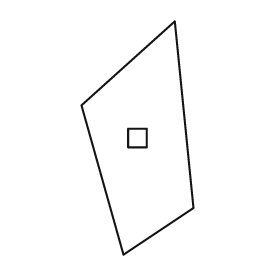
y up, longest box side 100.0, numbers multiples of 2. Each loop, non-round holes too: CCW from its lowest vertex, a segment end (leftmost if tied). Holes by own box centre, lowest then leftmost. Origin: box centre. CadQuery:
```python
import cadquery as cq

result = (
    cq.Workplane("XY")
    .moveTo(-6.0, -50.0)
    .lineTo(24.0, -30.0)
    .lineTo(16.0, 50.0)
    .lineTo(-24.0, 14.0)
    .close()
    .moveTo(-4.0, -4.0)
    .lineTo(4.0, -4.0)
    .lineTo(4.0, 4.0)
    .lineTo(-4.0, 4.0)
    .close()
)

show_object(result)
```